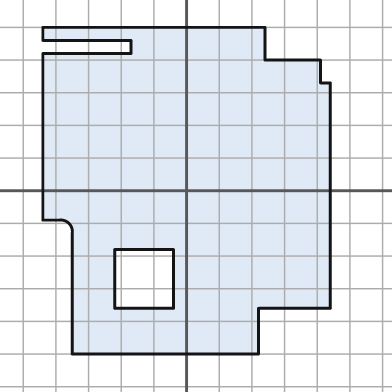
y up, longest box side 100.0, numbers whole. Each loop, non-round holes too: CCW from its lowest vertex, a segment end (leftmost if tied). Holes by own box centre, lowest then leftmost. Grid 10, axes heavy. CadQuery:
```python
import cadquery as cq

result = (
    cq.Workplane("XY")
    .moveTo(-35.0, -50.0)
    .lineTo(22.0, -50.0)
    .lineTo(22.0, -36.0)
    .lineTo(44.0, -36.0)
    .lineTo(44.0, 33.0)
    .lineTo(41.0, 33.0)
    .lineTo(41.0, 40.0)
    .lineTo(24.0, 40.0)
    .lineTo(24.0, 50.0)
    .lineTo(-44.0, 50.0)
    .lineTo(-44.0, 46.0)
    .lineTo(-17.0, 46.0)
    .lineTo(-17.0, 42.0)
    .lineTo(-44.0, 42.0)
    .lineTo(-44.0, -9.0)
    .lineTo(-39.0, -9.0)
    .threePointArc((-36.0, -10.0), (-35.0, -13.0))
    .close()
    .moveTo(-22.0, -36.0)
    .lineTo(-4.0, -36.0)
    .lineTo(-4.0, -18.0)
    .lineTo(-22.0, -18.0)
    .close()
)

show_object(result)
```